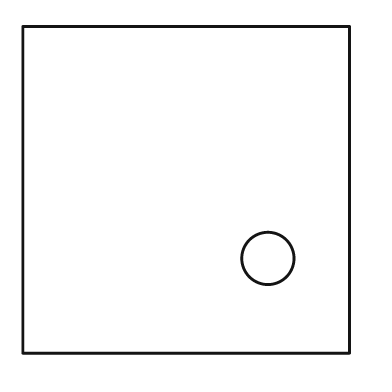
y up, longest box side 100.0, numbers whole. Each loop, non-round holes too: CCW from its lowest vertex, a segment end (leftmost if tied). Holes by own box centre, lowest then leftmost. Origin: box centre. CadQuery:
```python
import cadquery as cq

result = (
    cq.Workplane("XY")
    .moveTo(-50.0, -50.0)
    .lineTo(50.0, -50.0)
    .lineTo(50.0, 50.0)
    .lineTo(-50.0, 50.0)
    .close()
    .moveTo(25.0, -21.0)
    .circle(8.0)
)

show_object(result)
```